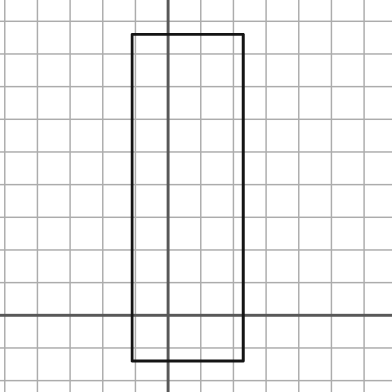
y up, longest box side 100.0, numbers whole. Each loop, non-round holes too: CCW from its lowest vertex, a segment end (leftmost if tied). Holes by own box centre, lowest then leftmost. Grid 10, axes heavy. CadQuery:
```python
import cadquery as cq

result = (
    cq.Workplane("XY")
    .moveTo(-11.0, -14.0)
    .lineTo(23.0, -14.0)
    .lineTo(23.0, 86.0)
    .lineTo(-11.0, 86.0)
    .close()
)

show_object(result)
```